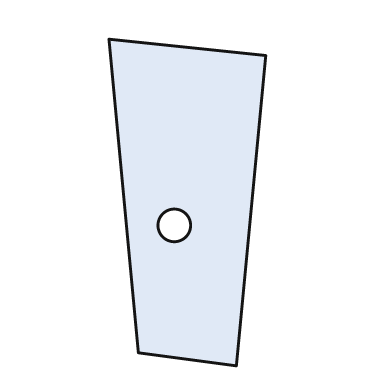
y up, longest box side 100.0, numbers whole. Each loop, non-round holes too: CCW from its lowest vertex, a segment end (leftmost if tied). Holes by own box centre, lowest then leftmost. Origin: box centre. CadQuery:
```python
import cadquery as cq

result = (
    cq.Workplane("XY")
    .moveTo(15.0, -50.0)
    .lineTo(24.0, 45.0)
    .lineTo(-24.0, 50.0)
    .lineTo(-15.0, -46.0)
    .close()
    .moveTo(-4.0, -7.0)
    .circle(5.0)
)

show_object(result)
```